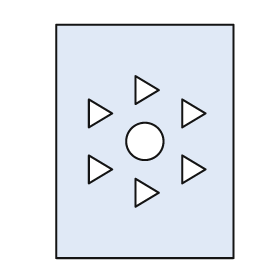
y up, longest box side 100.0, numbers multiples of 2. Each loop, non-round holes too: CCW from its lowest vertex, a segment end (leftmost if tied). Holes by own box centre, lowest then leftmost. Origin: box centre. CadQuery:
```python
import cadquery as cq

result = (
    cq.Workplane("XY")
    .moveTo(-38.0, -50.0)
    .lineTo(38.0, -50.0)
    .lineTo(38.0, 50.0)
    .lineTo(-38.0, 50.0)
    .close()
    .moveTo(-4.0, -28.0)
    .lineTo(6.0, -22.0)
    .lineTo(-4.0, -16.0)
    .close()
    .moveTo(-24.0, -18.0)
    .lineTo(-14.0, -12.0)
    .lineTo(-24.0, -6.0)
    .close()
    .moveTo(16.0, -18.0)
    .lineTo(26.0, -12.0)
    .lineTo(16.0, -6.0)
    .close()
    .moveTo(0.0, 0.0)
    .circle(8.0)
    .moveTo(-24.0, 6.0)
    .lineTo(-14.0, 12.0)
    .lineTo(-24.0, 18.0)
    .close()
    .moveTo(16.0, 6.0)
    .lineTo(26.0, 12.0)
    .lineTo(16.0, 18.0)
    .close()
    .moveTo(-4.0, 16.0)
    .lineTo(6.0, 22.0)
    .lineTo(-4.0, 28.0)
    .close()
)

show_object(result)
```